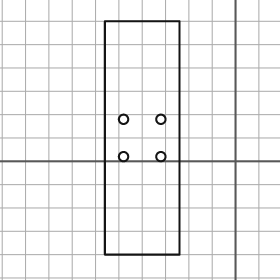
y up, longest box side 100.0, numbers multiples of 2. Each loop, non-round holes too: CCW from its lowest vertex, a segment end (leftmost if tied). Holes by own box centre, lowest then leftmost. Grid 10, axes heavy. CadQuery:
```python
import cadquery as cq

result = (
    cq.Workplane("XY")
    .moveTo(-56.0, -40.0)
    .lineTo(-24.0, -40.0)
    .lineTo(-24.0, 60.0)
    .lineTo(-56.0, 60.0)
    .close()
    .moveTo(-48.0, 2.0)
    .circle(2.0)
    .moveTo(-32.0, 2.0)
    .circle(2.0)
    .moveTo(-48.0, 18.0)
    .circle(2.0)
    .moveTo(-32.0, 18.0)
    .circle(2.0)
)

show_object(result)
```